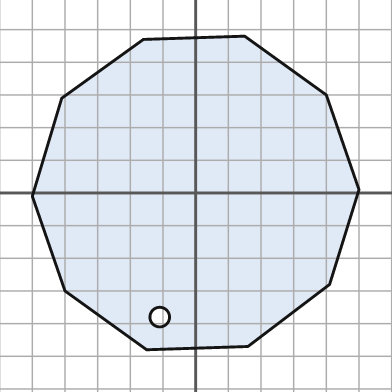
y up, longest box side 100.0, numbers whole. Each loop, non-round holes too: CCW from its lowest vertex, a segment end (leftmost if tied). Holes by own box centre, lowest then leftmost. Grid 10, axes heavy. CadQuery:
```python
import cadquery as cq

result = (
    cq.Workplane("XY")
    .moveTo(-15.0, -48.0)
    .lineTo(16.0, -47.0)
    .lineTo(41.0, -28.0)
    .lineTo(50.0, 1.0)
    .lineTo(40.0, 30.0)
    .lineTo(15.0, 48.0)
    .lineTo(-16.0, 47.0)
    .lineTo(-41.0, 29.0)
    .lineTo(-50.0, -1.0)
    .lineTo(-40.0, -30.0)
    .close()
    .moveTo(-11.0, -38.0)
    .circle(3.0)
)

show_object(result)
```